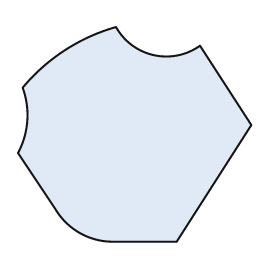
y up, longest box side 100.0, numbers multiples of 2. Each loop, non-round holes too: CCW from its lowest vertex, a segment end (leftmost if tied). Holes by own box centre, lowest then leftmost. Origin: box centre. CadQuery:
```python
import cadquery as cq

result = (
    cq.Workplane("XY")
    .moveTo(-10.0, -46.0)
    .lineTo(18.0, -46.0)
    .lineTo(50.0, 4.0)
    .lineTo(28.0, 38.0)
    .threePointArc((8.0, 34.0), (-8.0, 46.0))
    .threePointArc((-30.0, 36.0), (-48.0, 20.0))
    .threePointArc((-46.0, 6.0), (-50.0, -8.0))
    .lineTo(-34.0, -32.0)
    .threePointArc((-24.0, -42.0), (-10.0, -46.0))
    .close()
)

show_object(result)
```